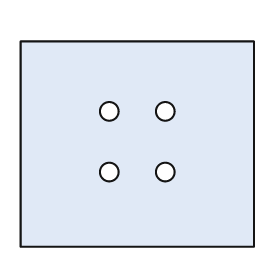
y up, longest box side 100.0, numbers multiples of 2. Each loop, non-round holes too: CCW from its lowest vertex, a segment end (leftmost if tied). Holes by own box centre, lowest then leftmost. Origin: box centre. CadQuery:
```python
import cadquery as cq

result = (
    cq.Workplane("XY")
    .moveTo(-50.0, -44.0)
    .lineTo(50.0, -44.0)
    .lineTo(50.0, 44.0)
    .lineTo(-50.0, 44.0)
    .close()
    .moveTo(-12.0, -12.0)
    .circle(4.0)
    .moveTo(12.0, -12.0)
    .circle(4.0)
    .moveTo(-12.0, 14.0)
    .circle(4.0)
    .moveTo(12.0, 14.0)
    .circle(4.0)
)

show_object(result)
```